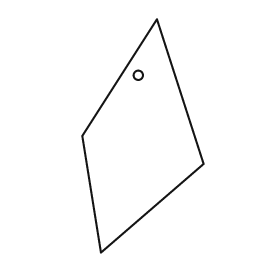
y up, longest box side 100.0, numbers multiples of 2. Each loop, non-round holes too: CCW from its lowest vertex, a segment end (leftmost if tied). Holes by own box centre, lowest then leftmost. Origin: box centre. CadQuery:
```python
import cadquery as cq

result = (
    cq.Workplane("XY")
    .moveTo(-18.0, -50.0)
    .lineTo(26.0, -12.0)
    .lineTo(6.0, 50.0)
    .lineTo(-26.0, 0.0)
    .close()
    .moveTo(-2.0, 26.0)
    .circle(2.0)
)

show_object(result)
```